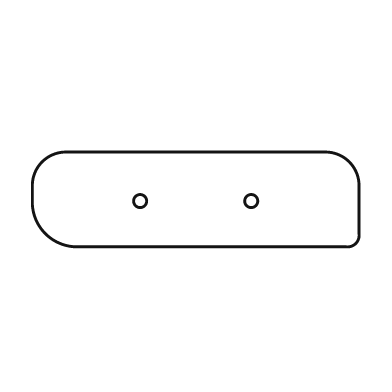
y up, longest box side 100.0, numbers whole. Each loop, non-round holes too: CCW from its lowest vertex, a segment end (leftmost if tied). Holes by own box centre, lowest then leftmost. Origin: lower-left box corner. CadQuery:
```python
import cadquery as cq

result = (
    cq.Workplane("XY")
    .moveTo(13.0, 0.0)
    .lineTo(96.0, 0.0)
    .threePointArc((99.0, 1.0), (100.0, 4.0))
    .lineTo(100.0, 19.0)
    .threePointArc((97.0, 26.0), (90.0, 29.0))
    .lineTo(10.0, 29.0)
    .threePointArc((3.0, 26.0), (0.0, 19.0))
    .lineTo(0.0, 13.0)
    .threePointArc((4.0, 4.0), (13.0, 0.0))
    .close()
    .moveTo(33.0, 14.0)
    .circle(2.0)
    .moveTo(67.0, 14.0)
    .circle(2.0)
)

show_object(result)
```